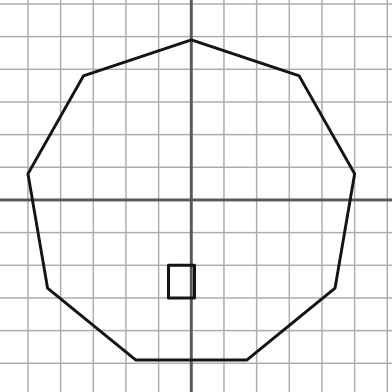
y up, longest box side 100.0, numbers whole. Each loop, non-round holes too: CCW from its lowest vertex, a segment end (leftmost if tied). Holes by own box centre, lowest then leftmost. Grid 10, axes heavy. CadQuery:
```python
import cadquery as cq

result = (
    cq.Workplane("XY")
    .moveTo(-17.0, -49.0)
    .lineTo(17.0, -49.0)
    .lineTo(44.0, -27.0)
    .lineTo(50.0, 8.0)
    .lineTo(33.0, 38.0)
    .lineTo(0.0, 49.0)
    .lineTo(-33.0, 38.0)
    .lineTo(-50.0, 8.0)
    .lineTo(-44.0, -27.0)
    .close()
    .moveTo(-7.0, -30.0)
    .lineTo(1.0, -30.0)
    .lineTo(1.0, -20.0)
    .lineTo(-7.0, -20.0)
    .close()
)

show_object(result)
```